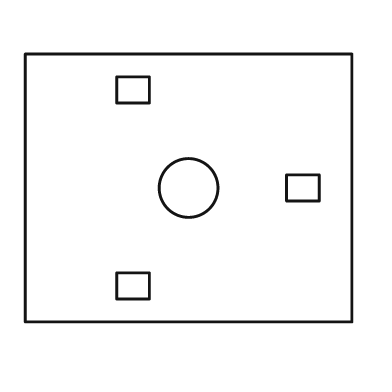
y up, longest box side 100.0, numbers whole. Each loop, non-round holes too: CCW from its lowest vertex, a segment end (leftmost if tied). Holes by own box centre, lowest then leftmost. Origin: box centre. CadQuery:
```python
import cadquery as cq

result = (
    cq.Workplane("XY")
    .moveTo(-50.0, -41.0)
    .lineTo(50.0, -41.0)
    .lineTo(50.0, 41.0)
    .lineTo(-50.0, 41.0)
    .close()
    .moveTo(-22.0, -34.0)
    .lineTo(-12.0, -34.0)
    .lineTo(-12.0, -26.0)
    .lineTo(-22.0, -26.0)
    .close()
    .moveTo(0.0, 0.0)
    .circle(9.0)
    .moveTo(30.0, -4.0)
    .lineTo(40.0, -4.0)
    .lineTo(40.0, 4.0)
    .lineTo(30.0, 4.0)
    .close()
    .moveTo(-22.0, 26.0)
    .lineTo(-12.0, 26.0)
    .lineTo(-12.0, 34.0)
    .lineTo(-22.0, 34.0)
    .close()
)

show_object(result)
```